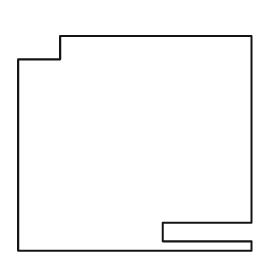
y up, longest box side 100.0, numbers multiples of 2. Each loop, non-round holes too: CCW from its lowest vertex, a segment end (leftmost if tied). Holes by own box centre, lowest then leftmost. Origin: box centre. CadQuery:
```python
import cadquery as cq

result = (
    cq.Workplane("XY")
    .moveTo(-50.0, -46.0)
    .lineTo(50.0, -46.0)
    .lineTo(50.0, -42.0)
    .lineTo(12.0, -42.0)
    .lineTo(12.0, -34.0)
    .lineTo(50.0, -34.0)
    .lineTo(50.0, 46.0)
    .lineTo(-32.0, 46.0)
    .lineTo(-32.0, 36.0)
    .lineTo(-50.0, 36.0)
    .close()
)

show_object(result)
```